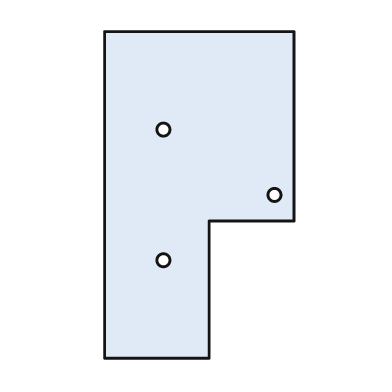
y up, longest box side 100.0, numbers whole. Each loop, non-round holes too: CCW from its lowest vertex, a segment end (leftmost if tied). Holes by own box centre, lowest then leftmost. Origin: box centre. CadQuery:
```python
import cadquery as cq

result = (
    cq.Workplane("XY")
    .moveTo(-29.0, -50.0)
    .lineTo(3.0, -50.0)
    .lineTo(3.0, -8.0)
    .lineTo(29.0, -8.0)
    .lineTo(29.0, 50.0)
    .lineTo(-29.0, 50.0)
    .close()
    .moveTo(-11.0, -20.0)
    .circle(2.0)
    .moveTo(23.0, 0.0)
    .circle(2.0)
    .moveTo(-11.0, 20.0)
    .circle(2.0)
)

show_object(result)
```